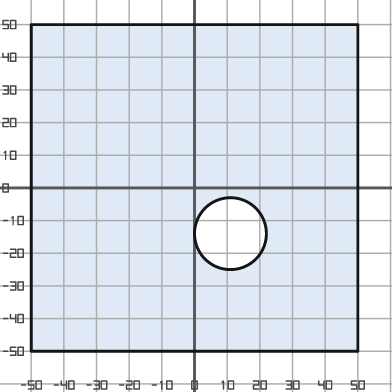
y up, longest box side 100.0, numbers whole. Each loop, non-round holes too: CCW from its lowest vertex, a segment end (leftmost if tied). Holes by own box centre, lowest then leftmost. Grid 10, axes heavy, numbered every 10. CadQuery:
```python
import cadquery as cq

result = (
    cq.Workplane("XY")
    .moveTo(-50.0, -50.0)
    .lineTo(50.0, -50.0)
    .lineTo(50.0, 50.0)
    .lineTo(-50.0, 50.0)
    .close()
    .moveTo(11.0, -14.0)
    .circle(11.0)
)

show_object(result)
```